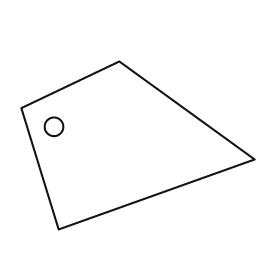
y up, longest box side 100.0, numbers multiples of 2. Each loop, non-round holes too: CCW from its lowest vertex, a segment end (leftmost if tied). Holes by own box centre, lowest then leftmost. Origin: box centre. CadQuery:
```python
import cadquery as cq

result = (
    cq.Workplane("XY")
    .moveTo(-34.0, -36.0)
    .lineTo(50.0, -6.0)
    .lineTo(-8.0, 36.0)
    .lineTo(-50.0, 16.0)
    .close()
    .moveTo(-36.0, 8.0)
    .circle(4.0)
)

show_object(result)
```